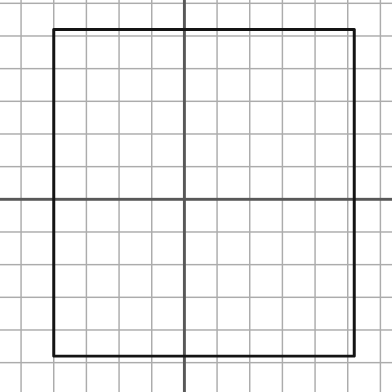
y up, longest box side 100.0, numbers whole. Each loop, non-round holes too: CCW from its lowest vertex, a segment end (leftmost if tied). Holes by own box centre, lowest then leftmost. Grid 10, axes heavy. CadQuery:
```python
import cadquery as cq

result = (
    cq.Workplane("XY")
    .moveTo(-40.0, -48.0)
    .lineTo(52.0, -48.0)
    .lineTo(52.0, 52.0)
    .lineTo(-40.0, 52.0)
    .close()
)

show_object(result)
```